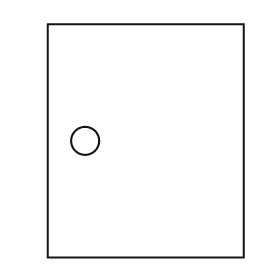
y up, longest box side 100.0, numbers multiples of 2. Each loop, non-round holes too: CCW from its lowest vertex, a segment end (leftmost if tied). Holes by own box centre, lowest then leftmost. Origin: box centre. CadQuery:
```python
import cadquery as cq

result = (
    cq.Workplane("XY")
    .moveTo(-42.0, -50.0)
    .lineTo(42.0, -50.0)
    .lineTo(42.0, 50.0)
    .lineTo(-42.0, 50.0)
    .close()
    .moveTo(-26.0, 0.0)
    .circle(6.0)
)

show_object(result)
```